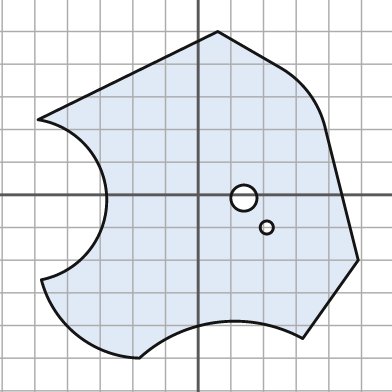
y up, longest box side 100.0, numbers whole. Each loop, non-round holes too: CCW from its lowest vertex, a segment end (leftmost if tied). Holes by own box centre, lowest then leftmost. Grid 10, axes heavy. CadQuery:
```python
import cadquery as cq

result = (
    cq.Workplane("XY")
    .moveTo(-18.0, -50.0)
    .threePointArc((6.0, -39.0), (32.0, -44.0))
    .lineTo(49.0, -20.0)
    .lineTo(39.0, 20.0)
    .threePointArc((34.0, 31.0), (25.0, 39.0))
    .lineTo(6.0, 50.0)
    .lineTo(-49.0, 23.0)
    .threePointArc((-28.0, -1.0), (-48.0, -26.0))
    .threePointArc((-37.0, -43.0), (-18.0, -50.0))
    .close()
    .moveTo(21.0, -10.0)
    .circle(2.0)
    .moveTo(14.0, -1.0)
    .circle(4.0)
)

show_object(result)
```